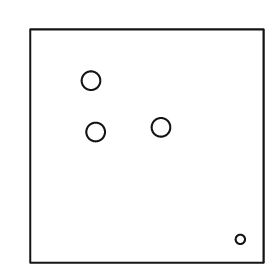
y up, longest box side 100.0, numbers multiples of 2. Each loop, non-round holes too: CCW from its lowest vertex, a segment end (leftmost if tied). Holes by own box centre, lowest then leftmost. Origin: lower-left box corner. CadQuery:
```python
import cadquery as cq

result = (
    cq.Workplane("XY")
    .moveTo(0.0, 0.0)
    .lineTo(100.0, 0.0)
    .lineTo(100.0, 100.0)
    .lineTo(0.0, 100.0)
    .close()
    .moveTo(90.0, 10.0)
    .circle(2.0)
    .moveTo(28.0, 56.0)
    .circle(4.0)
    .moveTo(56.0, 58.0)
    .circle(4.0)
    .moveTo(26.0, 78.0)
    .circle(4.0)
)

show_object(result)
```